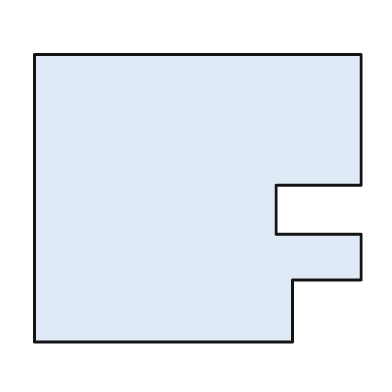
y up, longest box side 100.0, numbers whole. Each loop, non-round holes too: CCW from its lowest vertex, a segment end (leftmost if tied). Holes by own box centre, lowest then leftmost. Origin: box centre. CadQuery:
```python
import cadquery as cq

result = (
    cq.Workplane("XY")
    .moveTo(-50.0, -44.0)
    .lineTo(29.0, -44.0)
    .lineTo(29.0, -25.0)
    .lineTo(50.0, -25.0)
    .lineTo(50.0, -11.0)
    .lineTo(24.0, -11.0)
    .lineTo(24.0, 4.0)
    .lineTo(50.0, 4.0)
    .lineTo(50.0, 44.0)
    .lineTo(-50.0, 44.0)
    .close()
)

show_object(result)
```